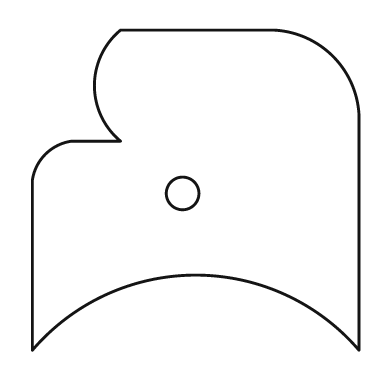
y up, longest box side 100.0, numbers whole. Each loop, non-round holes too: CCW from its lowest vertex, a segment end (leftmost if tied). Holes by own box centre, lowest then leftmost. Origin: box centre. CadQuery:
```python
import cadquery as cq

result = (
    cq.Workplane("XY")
    .moveTo(-50.0, -49.0)
    .threePointArc((0.0, -26.0), (50.0, -49.0))
    .lineTo(50.0, 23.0)
    .threePointArc((42.0, 41.0), (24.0, 49.0))
    .lineTo(-23.0, 49.0)
    .threePointArc((-31.0, 32.0), (-23.0, 15.0))
    .lineTo(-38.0, 15.0)
    .threePointArc((-46.0, 11.0), (-50.0, 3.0))
    .close()
    .moveTo(-4.0, -1.0)
    .circle(5.0)
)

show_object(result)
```